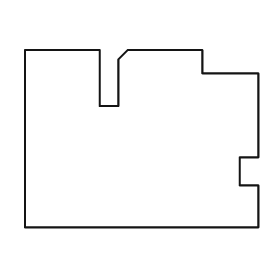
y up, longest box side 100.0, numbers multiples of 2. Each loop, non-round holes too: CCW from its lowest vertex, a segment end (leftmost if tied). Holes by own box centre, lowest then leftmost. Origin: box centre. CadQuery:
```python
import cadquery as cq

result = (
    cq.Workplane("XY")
    .moveTo(-50.0, -38.0)
    .lineTo(50.0, -38.0)
    .lineTo(50.0, -20.0)
    .lineTo(42.0, -20.0)
    .lineTo(42.0, -8.0)
    .lineTo(50.0, -8.0)
    .lineTo(50.0, 28.0)
    .lineTo(26.0, 28.0)
    .lineTo(26.0, 38.0)
    .lineTo(-6.0, 38.0)
    .lineTo(-10.0, 34.0)
    .lineTo(-10.0, 14.0)
    .lineTo(-18.0, 14.0)
    .lineTo(-18.0, 38.0)
    .lineTo(-50.0, 38.0)
    .close()
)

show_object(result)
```